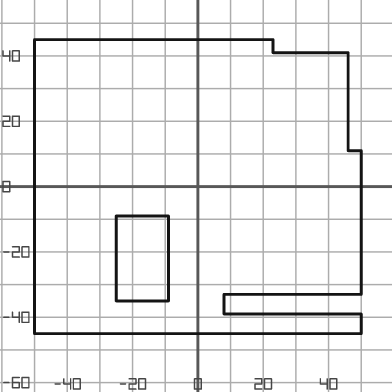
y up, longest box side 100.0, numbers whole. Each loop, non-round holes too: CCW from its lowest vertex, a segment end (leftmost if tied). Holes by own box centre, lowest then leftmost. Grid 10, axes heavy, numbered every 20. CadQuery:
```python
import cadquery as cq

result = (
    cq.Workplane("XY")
    .moveTo(-50.0, -45.0)
    .lineTo(50.0, -45.0)
    .lineTo(50.0, -39.0)
    .lineTo(8.0, -39.0)
    .lineTo(8.0, -33.0)
    .lineTo(50.0, -33.0)
    .lineTo(50.0, 11.0)
    .lineTo(46.0, 11.0)
    .lineTo(46.0, 41.0)
    .lineTo(23.0, 41.0)
    .lineTo(23.0, 45.0)
    .lineTo(-50.0, 45.0)
    .close()
    .moveTo(-25.0, -35.0)
    .lineTo(-9.0, -35.0)
    .lineTo(-9.0, -9.0)
    .lineTo(-25.0, -9.0)
    .close()
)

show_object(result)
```